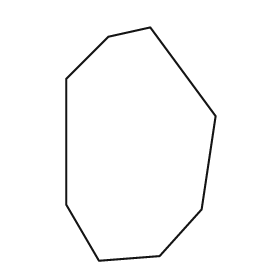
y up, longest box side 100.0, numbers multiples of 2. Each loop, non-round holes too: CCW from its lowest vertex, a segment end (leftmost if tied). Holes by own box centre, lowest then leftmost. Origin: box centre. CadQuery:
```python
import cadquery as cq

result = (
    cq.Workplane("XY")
    .moveTo(-18.0, -50.0)
    .lineTo(8.0, -48.0)
    .lineTo(26.0, -28.0)
    .lineTo(32.0, 12.0)
    .lineTo(4.0, 50.0)
    .lineTo(-14.0, 46.0)
    .lineTo(-32.0, 28.0)
    .lineTo(-32.0, -26.0)
    .close()
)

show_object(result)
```